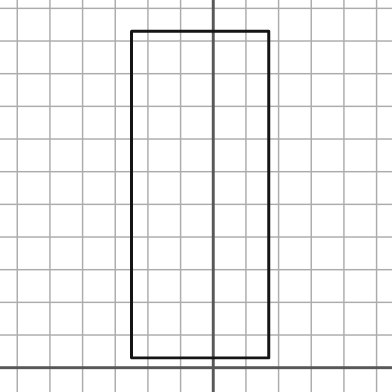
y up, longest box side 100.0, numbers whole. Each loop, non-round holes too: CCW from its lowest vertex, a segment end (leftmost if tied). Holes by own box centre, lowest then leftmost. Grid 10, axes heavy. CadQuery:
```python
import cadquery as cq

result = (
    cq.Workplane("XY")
    .moveTo(-25.0, 3.0)
    .lineTo(17.0, 3.0)
    .lineTo(17.0, 103.0)
    .lineTo(-25.0, 103.0)
    .close()
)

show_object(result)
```